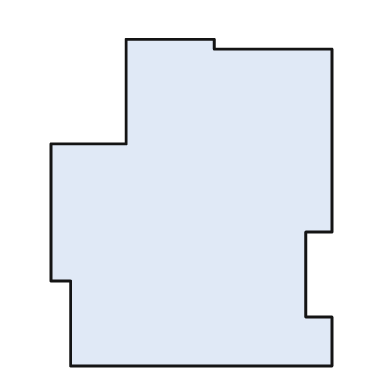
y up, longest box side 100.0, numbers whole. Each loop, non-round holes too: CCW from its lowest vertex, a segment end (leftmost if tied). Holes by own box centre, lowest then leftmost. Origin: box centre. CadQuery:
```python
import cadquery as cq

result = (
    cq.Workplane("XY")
    .moveTo(-37.0, -50.0)
    .lineTo(43.0, -50.0)
    .lineTo(43.0, -35.0)
    .lineTo(35.0, -35.0)
    .lineTo(35.0, -9.0)
    .lineTo(43.0, -9.0)
    .lineTo(43.0, 47.0)
    .lineTo(7.0, 47.0)
    .lineTo(7.0, 50.0)
    .lineTo(-20.0, 50.0)
    .lineTo(-20.0, 18.0)
    .lineTo(-43.0, 18.0)
    .lineTo(-43.0, -24.0)
    .lineTo(-37.0, -24.0)
    .close()
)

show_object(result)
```